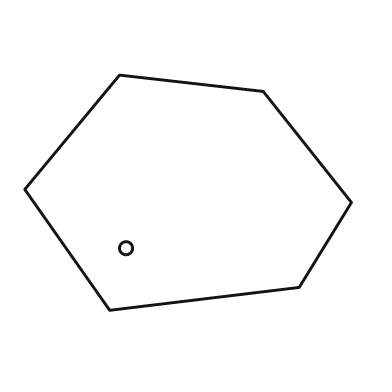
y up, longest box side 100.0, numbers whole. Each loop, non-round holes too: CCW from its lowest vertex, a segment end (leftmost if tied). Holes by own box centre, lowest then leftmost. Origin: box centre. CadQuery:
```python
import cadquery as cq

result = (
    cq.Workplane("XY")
    .moveTo(-24.0, -36.0)
    .lineTo(34.0, -29.0)
    .lineTo(50.0, -3.0)
    .lineTo(23.0, 31.0)
    .lineTo(-21.0, 36.0)
    .lineTo(-50.0, 1.0)
    .close()
    .moveTo(-19.0, -17.0)
    .circle(2.0)
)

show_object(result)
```